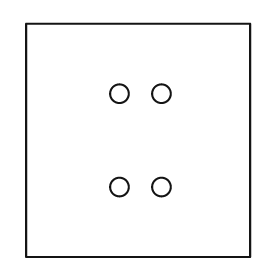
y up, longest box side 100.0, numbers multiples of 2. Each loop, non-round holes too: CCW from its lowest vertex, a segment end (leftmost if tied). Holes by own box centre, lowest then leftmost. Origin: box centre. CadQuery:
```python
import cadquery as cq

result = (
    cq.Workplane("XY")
    .moveTo(-48.0, -50.0)
    .lineTo(48.0, -50.0)
    .lineTo(48.0, 50.0)
    .lineTo(-48.0, 50.0)
    .close()
    .moveTo(-8.0, -20.0)
    .circle(4.0)
    .moveTo(10.0, -20.0)
    .circle(4.0)
    .moveTo(-8.0, 20.0)
    .circle(4.0)
    .moveTo(10.0, 20.0)
    .circle(4.0)
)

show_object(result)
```